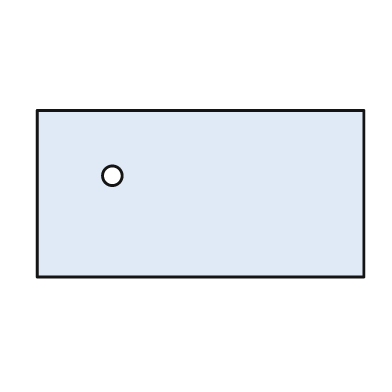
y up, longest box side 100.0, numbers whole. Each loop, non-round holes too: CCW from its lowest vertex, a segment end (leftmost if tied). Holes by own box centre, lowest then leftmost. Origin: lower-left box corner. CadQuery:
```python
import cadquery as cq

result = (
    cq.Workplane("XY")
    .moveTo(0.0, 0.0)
    .lineTo(100.0, 0.0)
    .lineTo(100.0, 51.0)
    .lineTo(0.0, 51.0)
    .close()
    .moveTo(23.0, 31.0)
    .circle(3.0)
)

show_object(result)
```